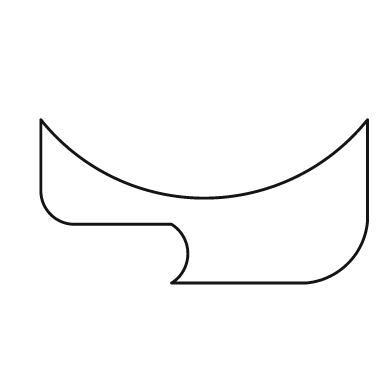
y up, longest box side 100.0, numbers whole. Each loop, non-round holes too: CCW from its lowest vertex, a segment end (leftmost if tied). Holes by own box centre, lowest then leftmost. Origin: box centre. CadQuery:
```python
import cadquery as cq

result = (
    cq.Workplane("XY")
    .moveTo(-10.0, -25.0)
    .lineTo(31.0, -25.0)
    .threePointArc((44.0, -19.0), (50.0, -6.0))
    .lineTo(50.0, 25.0)
    .threePointArc((0.0, 1.0), (-50.0, 25.0))
    .lineTo(-50.0, 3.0)
    .threePointArc((-47.0, -4.0), (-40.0, -7.0))
    .lineTo(-10.0, -7.0)
    .threePointArc((-5.0, -16.0), (-10.0, -25.0))
    .close()
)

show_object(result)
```